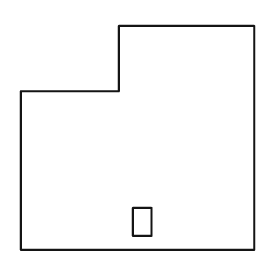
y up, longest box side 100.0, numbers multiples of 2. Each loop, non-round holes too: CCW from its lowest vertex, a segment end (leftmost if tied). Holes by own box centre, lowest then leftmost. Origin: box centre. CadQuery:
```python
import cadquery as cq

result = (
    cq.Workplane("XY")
    .moveTo(-50.0, -48.0)
    .lineTo(50.0, -48.0)
    .lineTo(50.0, 48.0)
    .lineTo(-8.0, 48.0)
    .lineTo(-8.0, 20.0)
    .lineTo(-50.0, 20.0)
    .close()
    .moveTo(-2.0, -42.0)
    .lineTo(6.0, -42.0)
    .lineTo(6.0, -30.0)
    .lineTo(-2.0, -30.0)
    .close()
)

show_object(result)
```